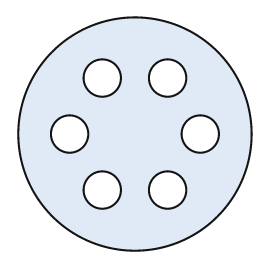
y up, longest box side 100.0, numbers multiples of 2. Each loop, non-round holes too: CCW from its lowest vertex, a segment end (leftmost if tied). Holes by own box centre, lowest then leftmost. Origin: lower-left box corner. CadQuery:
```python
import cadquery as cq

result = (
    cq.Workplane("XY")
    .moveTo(50.0, 50.0)
    .circle(50.0)
    .moveTo(36.0, 26.0)
    .circle(8.0)
    .moveTo(64.0, 26.0)
    .circle(8.0)
    .moveTo(22.0, 50.0)
    .circle(8.0)
    .moveTo(78.0, 50.0)
    .circle(8.0)
    .moveTo(36.0, 74.0)
    .circle(8.0)
    .moveTo(64.0, 74.0)
    .circle(8.0)
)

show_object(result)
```